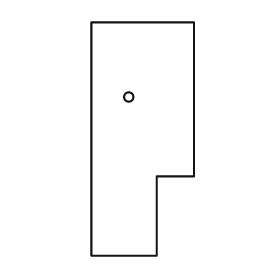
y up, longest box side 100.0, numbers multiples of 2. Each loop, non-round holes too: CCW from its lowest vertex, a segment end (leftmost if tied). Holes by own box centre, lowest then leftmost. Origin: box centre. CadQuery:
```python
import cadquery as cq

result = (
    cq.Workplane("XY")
    .moveTo(-22.0, -50.0)
    .lineTo(6.0, -50.0)
    .lineTo(6.0, -16.0)
    .lineTo(22.0, -16.0)
    .lineTo(22.0, 50.0)
    .lineTo(-22.0, 50.0)
    .close()
    .moveTo(-6.0, 18.0)
    .circle(2.0)
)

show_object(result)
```